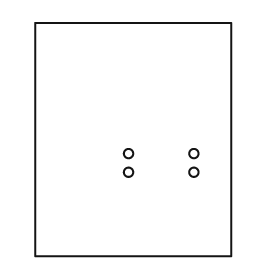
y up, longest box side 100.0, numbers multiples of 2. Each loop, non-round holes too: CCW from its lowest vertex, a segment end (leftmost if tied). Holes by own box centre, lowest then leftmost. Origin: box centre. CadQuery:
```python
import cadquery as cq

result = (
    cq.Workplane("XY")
    .moveTo(-42.0, -50.0)
    .lineTo(42.0, -50.0)
    .lineTo(42.0, 50.0)
    .lineTo(-42.0, 50.0)
    .close()
    .moveTo(-2.0, -14.0)
    .circle(2.0)
    .moveTo(26.0, -14.0)
    .circle(2.0)
    .moveTo(-2.0, -6.0)
    .circle(2.0)
    .moveTo(26.0, -6.0)
    .circle(2.0)
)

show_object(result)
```